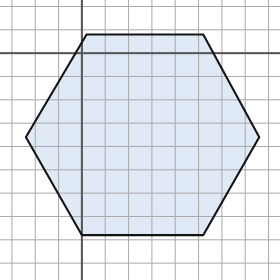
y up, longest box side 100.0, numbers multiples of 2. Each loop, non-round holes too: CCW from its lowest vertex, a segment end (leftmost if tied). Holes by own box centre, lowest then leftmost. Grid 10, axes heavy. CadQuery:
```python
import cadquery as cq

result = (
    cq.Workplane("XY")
    .moveTo(0.0, -78.0)
    .lineTo(52.0, -78.0)
    .lineTo(76.0, -36.0)
    .lineTo(52.0, 8.0)
    .lineTo(2.0, 8.0)
    .lineTo(-24.0, -36.0)
    .close()
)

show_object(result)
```